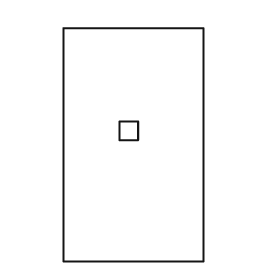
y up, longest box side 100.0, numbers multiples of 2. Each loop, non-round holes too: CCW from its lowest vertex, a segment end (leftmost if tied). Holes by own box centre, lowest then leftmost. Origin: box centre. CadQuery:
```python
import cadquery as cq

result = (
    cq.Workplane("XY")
    .moveTo(-30.0, -50.0)
    .lineTo(30.0, -50.0)
    .lineTo(30.0, 50.0)
    .lineTo(-30.0, 50.0)
    .close()
    .moveTo(-6.0, 2.0)
    .lineTo(2.0, 2.0)
    .lineTo(2.0, 10.0)
    .lineTo(-6.0, 10.0)
    .close()
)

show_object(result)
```